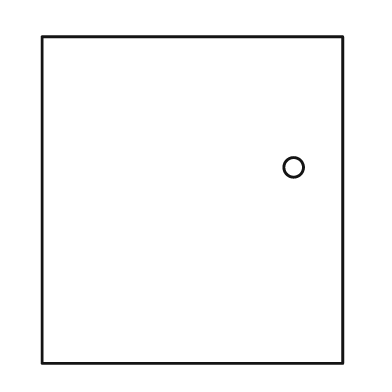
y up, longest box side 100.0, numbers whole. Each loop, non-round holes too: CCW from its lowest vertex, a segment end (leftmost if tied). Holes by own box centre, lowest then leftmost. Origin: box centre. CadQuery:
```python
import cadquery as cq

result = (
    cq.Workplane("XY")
    .moveTo(-46.0, -50.0)
    .lineTo(46.0, -50.0)
    .lineTo(46.0, 50.0)
    .lineTo(-46.0, 50.0)
    .close()
    .moveTo(31.0, 10.0)
    .circle(3.0)
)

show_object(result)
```